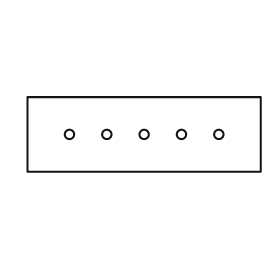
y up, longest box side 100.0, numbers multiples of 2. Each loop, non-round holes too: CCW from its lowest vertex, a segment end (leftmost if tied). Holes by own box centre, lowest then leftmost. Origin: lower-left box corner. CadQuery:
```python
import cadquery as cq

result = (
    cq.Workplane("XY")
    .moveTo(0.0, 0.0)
    .lineTo(100.0, 0.0)
    .lineTo(100.0, 32.0)
    .lineTo(0.0, 32.0)
    .close()
    .moveTo(18.0, 16.0)
    .circle(2.0)
    .moveTo(34.0, 16.0)
    .circle(2.0)
    .moveTo(50.0, 16.0)
    .circle(2.0)
    .moveTo(66.0, 16.0)
    .circle(2.0)
    .moveTo(82.0, 16.0)
    .circle(2.0)
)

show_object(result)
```